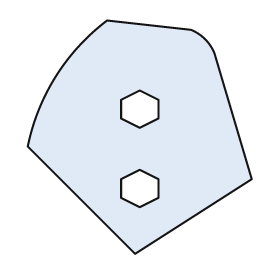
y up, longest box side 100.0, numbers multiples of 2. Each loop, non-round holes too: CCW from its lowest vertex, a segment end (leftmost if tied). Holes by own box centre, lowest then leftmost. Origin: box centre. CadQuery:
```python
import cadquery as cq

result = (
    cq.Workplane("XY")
    .moveTo(-2.0, -50.0)
    .lineTo(48.0, -18.0)
    .lineTo(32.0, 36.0)
    .threePointArc((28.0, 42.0), (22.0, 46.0))
    .lineTo(-14.0, 50.0)
    .threePointArc((-36.0, 26.0), (-48.0, -4.0))
    .close()
    .moveTo(0.0, -30.0)
    .lineTo(8.0, -26.0)
    .lineTo(8.0, -18.0)
    .lineTo(0.0, -14.0)
    .lineTo(-8.0, -18.0)
    .lineTo(-8.0, -26.0)
    .close()
    .moveTo(0.0, 4.0)
    .lineTo(8.0, 8.0)
    .lineTo(8.0, 16.0)
    .lineTo(0.0, 20.0)
    .lineTo(-8.0, 16.0)
    .lineTo(-8.0, 8.0)
    .close()
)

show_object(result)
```